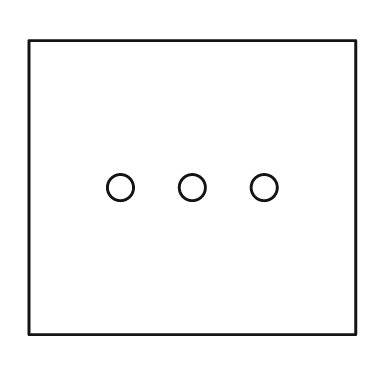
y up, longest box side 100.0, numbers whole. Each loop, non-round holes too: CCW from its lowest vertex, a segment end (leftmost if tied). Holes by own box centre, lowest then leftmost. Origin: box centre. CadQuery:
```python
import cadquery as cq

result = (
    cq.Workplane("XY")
    .moveTo(-50.0, -45.0)
    .lineTo(50.0, -45.0)
    .lineTo(50.0, 45.0)
    .lineTo(-50.0, 45.0)
    .close()
    .moveTo(-22.0, 0.0)
    .circle(4.0)
    .moveTo(0.0, 0.0)
    .circle(4.0)
    .moveTo(22.0, 0.0)
    .circle(4.0)
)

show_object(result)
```